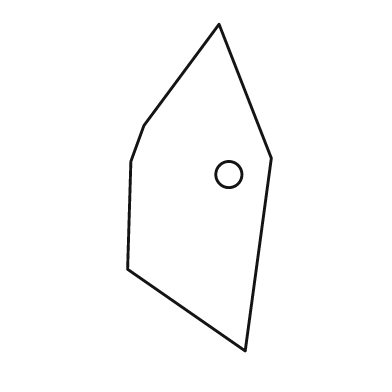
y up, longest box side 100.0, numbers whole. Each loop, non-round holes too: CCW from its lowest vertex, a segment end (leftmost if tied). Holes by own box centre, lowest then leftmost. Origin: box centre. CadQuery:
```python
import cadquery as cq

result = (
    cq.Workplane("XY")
    .moveTo(14.0, -50.0)
    .lineTo(22.0, 9.0)
    .lineTo(6.0, 50.0)
    .lineTo(-17.0, 19.0)
    .lineTo(-21.0, 8.0)
    .lineTo(-22.0, -25.0)
    .close()
    .moveTo(9.0, 4.0)
    .circle(4.0)
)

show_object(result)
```